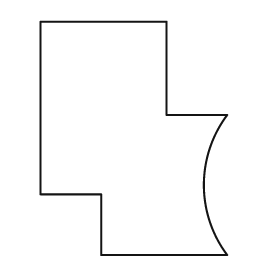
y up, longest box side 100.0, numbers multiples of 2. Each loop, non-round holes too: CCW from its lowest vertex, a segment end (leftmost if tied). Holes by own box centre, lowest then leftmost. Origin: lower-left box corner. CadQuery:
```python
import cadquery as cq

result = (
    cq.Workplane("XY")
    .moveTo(26.0, 0.0)
    .lineTo(80.0, 0.0)
    .threePointArc((70.0, 30.0), (80.0, 60.0))
    .lineTo(54.0, 60.0)
    .lineTo(54.0, 100.0)
    .lineTo(0.0, 100.0)
    .lineTo(0.0, 26.0)
    .lineTo(26.0, 26.0)
    .close()
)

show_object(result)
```